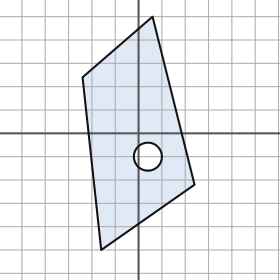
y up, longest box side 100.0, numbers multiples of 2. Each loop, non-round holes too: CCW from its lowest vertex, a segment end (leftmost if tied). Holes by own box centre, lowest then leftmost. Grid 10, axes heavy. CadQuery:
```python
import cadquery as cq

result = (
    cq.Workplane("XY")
    .moveTo(-16.0, -50.0)
    .lineTo(24.0, -22.0)
    .lineTo(6.0, 50.0)
    .lineTo(-24.0, 24.0)
    .close()
    .moveTo(4.0, -10.0)
    .circle(6.0)
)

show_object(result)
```